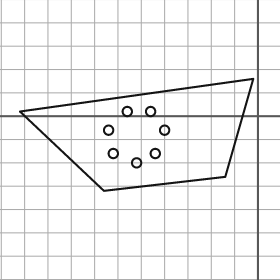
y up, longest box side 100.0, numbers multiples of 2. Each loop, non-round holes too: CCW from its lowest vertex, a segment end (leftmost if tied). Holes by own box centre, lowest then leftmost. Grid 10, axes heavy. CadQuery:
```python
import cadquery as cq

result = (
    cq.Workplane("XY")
    .moveTo(-66.0, -32.0)
    .lineTo(-14.0, -26.0)
    .lineTo(-2.0, 16.0)
    .lineTo(-102.0, 2.0)
    .close()
    .moveTo(-52.0, -20.0)
    .circle(2.0)
    .moveTo(-62.0, -16.0)
    .circle(2.0)
    .moveTo(-44.0, -16.0)
    .circle(2.0)
    .moveTo(-64.0, -6.0)
    .circle(2.0)
    .moveTo(-40.0, -6.0)
    .circle(2.0)
    .moveTo(-56.0, 2.0)
    .circle(2.0)
    .moveTo(-46.0, 2.0)
    .circle(2.0)
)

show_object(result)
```